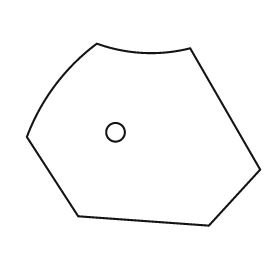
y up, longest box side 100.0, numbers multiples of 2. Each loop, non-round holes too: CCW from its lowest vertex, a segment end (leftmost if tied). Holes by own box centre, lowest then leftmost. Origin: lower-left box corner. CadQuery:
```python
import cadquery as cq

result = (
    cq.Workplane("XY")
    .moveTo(78.0, 0.0)
    .lineTo(100.0, 24.0)
    .lineTo(70.0, 76.0)
    .threePointArc((50.0, 74.0), (30.0, 78.0))
    .threePointArc((12.0, 60.0), (0.0, 38.0))
    .lineTo(22.0, 4.0)
    .close()
    .moveTo(38.0, 40.0)
    .circle(4.0)
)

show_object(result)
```